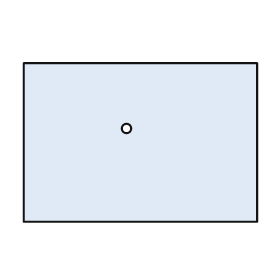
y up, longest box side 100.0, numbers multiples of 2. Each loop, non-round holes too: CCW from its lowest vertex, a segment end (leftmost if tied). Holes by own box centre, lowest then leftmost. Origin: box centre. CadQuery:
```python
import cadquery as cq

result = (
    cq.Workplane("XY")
    .moveTo(-50.0, -34.0)
    .lineTo(50.0, -34.0)
    .lineTo(50.0, 34.0)
    .lineTo(-50.0, 34.0)
    .close()
    .moveTo(-6.0, 6.0)
    .circle(2.0)
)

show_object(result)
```